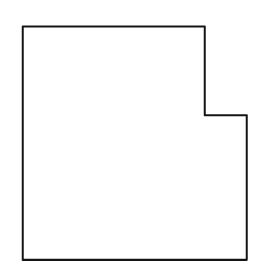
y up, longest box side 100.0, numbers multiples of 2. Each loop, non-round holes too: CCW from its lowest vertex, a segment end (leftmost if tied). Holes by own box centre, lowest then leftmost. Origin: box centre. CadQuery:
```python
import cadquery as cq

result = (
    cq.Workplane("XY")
    .moveTo(-48.0, -50.0)
    .lineTo(48.0, -50.0)
    .lineTo(48.0, 12.0)
    .lineTo(30.0, 12.0)
    .lineTo(30.0, 50.0)
    .lineTo(-48.0, 50.0)
    .close()
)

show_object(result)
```